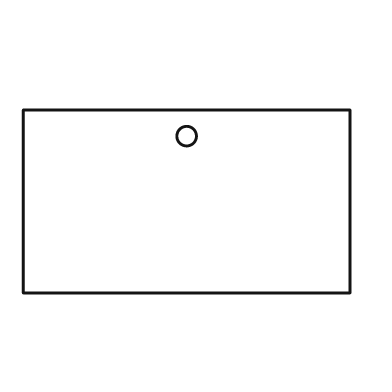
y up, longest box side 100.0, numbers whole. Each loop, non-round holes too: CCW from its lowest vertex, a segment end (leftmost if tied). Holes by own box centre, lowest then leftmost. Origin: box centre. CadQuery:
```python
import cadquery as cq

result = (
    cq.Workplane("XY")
    .moveTo(-50.0, -28.0)
    .lineTo(50.0, -28.0)
    .lineTo(50.0, 28.0)
    .lineTo(-50.0, 28.0)
    .close()
    .moveTo(0.0, 20.0)
    .circle(3.0)
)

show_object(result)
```